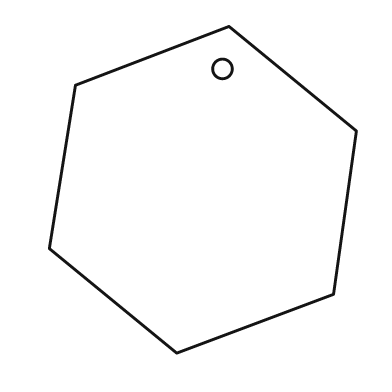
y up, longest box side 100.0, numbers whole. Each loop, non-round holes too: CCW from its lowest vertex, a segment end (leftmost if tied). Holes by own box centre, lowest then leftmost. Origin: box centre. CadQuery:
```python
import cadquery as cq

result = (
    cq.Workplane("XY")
    .moveTo(-8.0, -50.0)
    .lineTo(40.0, -32.0)
    .lineTo(47.0, 18.0)
    .lineTo(8.0, 50.0)
    .lineTo(-39.0, 32.0)
    .lineTo(-47.0, -18.0)
    .close()
    .moveTo(6.0, 37.0)
    .circle(3.0)
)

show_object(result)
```